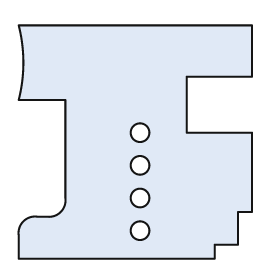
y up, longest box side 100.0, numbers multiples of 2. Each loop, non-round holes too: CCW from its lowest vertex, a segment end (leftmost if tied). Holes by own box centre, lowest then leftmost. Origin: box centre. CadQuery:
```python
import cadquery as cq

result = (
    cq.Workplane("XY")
    .moveTo(-50.0, -50.0)
    .lineTo(34.0, -50.0)
    .lineTo(34.0, -44.0)
    .lineTo(44.0, -44.0)
    .lineTo(44.0, -30.0)
    .lineTo(50.0, -30.0)
    .lineTo(50.0, 4.0)
    .lineTo(22.0, 4.0)
    .lineTo(22.0, 28.0)
    .lineTo(50.0, 28.0)
    .lineTo(50.0, 50.0)
    .lineTo(-50.0, 50.0)
    .threePointArc((-48.0, 34.0), (-50.0, 18.0))
    .lineTo(-30.0, 18.0)
    .lineTo(-30.0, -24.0)
    .threePointArc((-32.0, -30.0), (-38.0, -32.0))
    .lineTo(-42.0, -32.0)
    .threePointArc((-48.0, -34.0), (-50.0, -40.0))
    .close()
    .moveTo(2.0, -38.0)
    .circle(4.0)
    .moveTo(2.0, -24.0)
    .circle(4.0)
    .moveTo(2.0, -10.0)
    .circle(4.0)
    .moveTo(2.0, 4.0)
    .circle(4.0)
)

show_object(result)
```